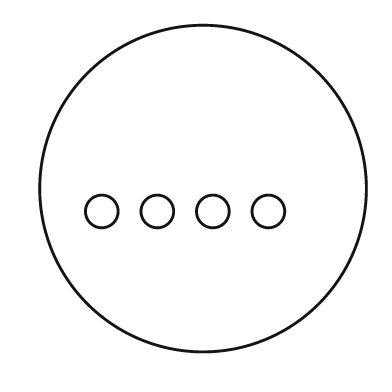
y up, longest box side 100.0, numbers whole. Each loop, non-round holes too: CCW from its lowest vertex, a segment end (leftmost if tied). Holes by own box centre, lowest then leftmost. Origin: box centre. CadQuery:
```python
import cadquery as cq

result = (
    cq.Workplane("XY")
    .moveTo(0.0, 0.0)
    .circle(50.0)
    .moveTo(-31.0, -7.0)
    .circle(5.0)
    .moveTo(-14.0, -7.0)
    .circle(5.0)
    .moveTo(3.0, -7.0)
    .circle(5.0)
    .moveTo(20.0, -7.0)
    .circle(5.0)
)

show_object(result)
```